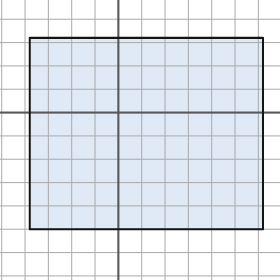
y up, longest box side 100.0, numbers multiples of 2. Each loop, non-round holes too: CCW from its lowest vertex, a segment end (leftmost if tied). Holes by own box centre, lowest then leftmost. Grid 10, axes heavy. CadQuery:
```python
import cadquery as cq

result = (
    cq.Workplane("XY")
    .moveTo(-38.0, -50.0)
    .lineTo(62.0, -50.0)
    .lineTo(62.0, 32.0)
    .lineTo(-38.0, 32.0)
    .close()
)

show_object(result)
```